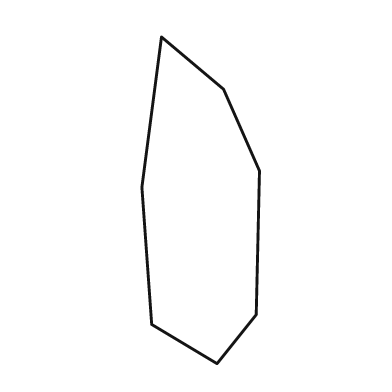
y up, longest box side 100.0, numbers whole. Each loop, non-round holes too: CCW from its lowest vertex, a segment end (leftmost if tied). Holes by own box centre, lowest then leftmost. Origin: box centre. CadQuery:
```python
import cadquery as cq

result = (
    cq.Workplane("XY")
    .moveTo(5.0, -50.0)
    .lineTo(17.0, -35.0)
    .lineTo(18.0, 9.0)
    .lineTo(7.0, 34.0)
    .lineTo(-12.0, 50.0)
    .lineTo(-18.0, 4.0)
    .lineTo(-15.0, -38.0)
    .close()
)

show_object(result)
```